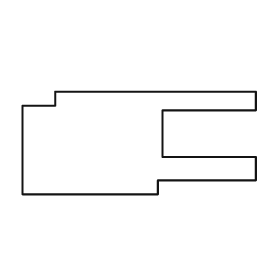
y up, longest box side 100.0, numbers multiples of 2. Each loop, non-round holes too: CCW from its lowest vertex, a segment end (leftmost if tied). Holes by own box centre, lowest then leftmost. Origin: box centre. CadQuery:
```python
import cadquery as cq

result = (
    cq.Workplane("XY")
    .moveTo(-50.0, -22.0)
    .lineTo(8.0, -22.0)
    .lineTo(8.0, -16.0)
    .lineTo(50.0, -16.0)
    .lineTo(50.0, -6.0)
    .lineTo(10.0, -6.0)
    .lineTo(10.0, 14.0)
    .lineTo(50.0, 14.0)
    .lineTo(50.0, 22.0)
    .lineTo(-36.0, 22.0)
    .lineTo(-36.0, 16.0)
    .lineTo(-50.0, 16.0)
    .close()
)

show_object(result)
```